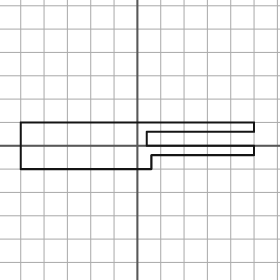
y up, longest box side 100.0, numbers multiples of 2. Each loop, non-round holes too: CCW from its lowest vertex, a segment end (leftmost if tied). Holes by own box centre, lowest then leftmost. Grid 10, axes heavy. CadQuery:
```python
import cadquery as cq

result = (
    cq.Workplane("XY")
    .moveTo(-50.0, -10.0)
    .lineTo(6.0, -10.0)
    .lineTo(6.0, -4.0)
    .lineTo(50.0, -4.0)
    .lineTo(50.0, 0.0)
    .lineTo(4.0, 0.0)
    .lineTo(4.0, 6.0)
    .lineTo(50.0, 6.0)
    .lineTo(50.0, 10.0)
    .lineTo(-50.0, 10.0)
    .close()
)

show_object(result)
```